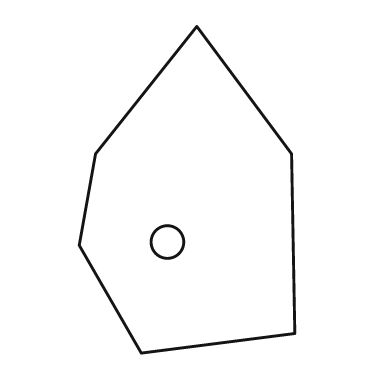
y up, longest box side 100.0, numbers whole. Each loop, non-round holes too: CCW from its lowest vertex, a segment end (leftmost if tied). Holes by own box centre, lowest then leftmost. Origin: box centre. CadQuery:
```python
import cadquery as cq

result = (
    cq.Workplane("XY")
    .moveTo(-14.0, -50.0)
    .lineTo(33.0, -44.0)
    .lineTo(32.0, 11.0)
    .lineTo(3.0, 50.0)
    .lineTo(-28.0, 11.0)
    .lineTo(-33.0, -17.0)
    .close()
    .moveTo(-6.0, -16.0)
    .circle(5.0)
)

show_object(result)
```